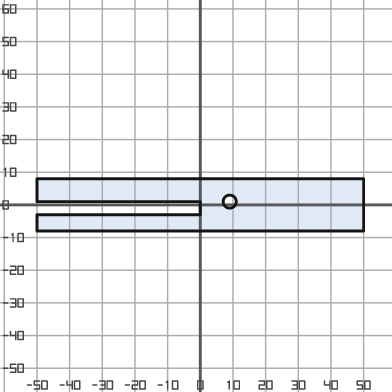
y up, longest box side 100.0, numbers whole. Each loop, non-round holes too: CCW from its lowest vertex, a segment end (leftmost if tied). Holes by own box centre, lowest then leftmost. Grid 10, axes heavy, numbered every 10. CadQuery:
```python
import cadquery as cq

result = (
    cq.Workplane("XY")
    .moveTo(-50.0, -8.0)
    .lineTo(50.0, -8.0)
    .lineTo(50.0, 8.0)
    .lineTo(-50.0, 8.0)
    .lineTo(-50.0, 1.0)
    .lineTo(0.0, 1.0)
    .lineTo(0.0, -3.0)
    .lineTo(-50.0, -3.0)
    .close()
    .moveTo(9.0, 1.0)
    .circle(2.0)
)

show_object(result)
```